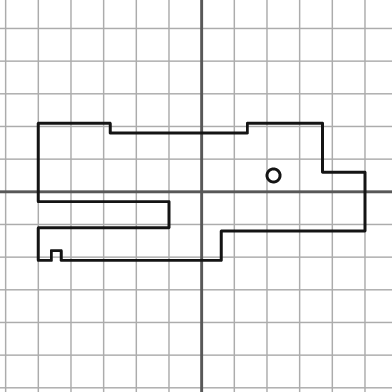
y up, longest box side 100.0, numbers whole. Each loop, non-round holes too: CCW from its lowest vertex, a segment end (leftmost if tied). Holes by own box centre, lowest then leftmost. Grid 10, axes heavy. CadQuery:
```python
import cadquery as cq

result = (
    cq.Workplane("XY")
    .moveTo(-50.0, -21.0)
    .lineTo(-46.0, -21.0)
    .lineTo(-46.0, -18.0)
    .lineTo(-43.0, -18.0)
    .lineTo(-43.0, -21.0)
    .lineTo(6.0, -21.0)
    .lineTo(6.0, -12.0)
    .lineTo(50.0, -12.0)
    .lineTo(50.0, 6.0)
    .lineTo(37.0, 6.0)
    .lineTo(37.0, 21.0)
    .lineTo(14.0, 21.0)
    .lineTo(14.0, 18.0)
    .lineTo(-28.0, 18.0)
    .lineTo(-28.0, 21.0)
    .lineTo(-50.0, 21.0)
    .lineTo(-50.0, -3.0)
    .lineTo(-10.0, -3.0)
    .lineTo(-10.0, -11.0)
    .lineTo(-50.0, -11.0)
    .close()
    .moveTo(22.0, 5.0)
    .circle(2.0)
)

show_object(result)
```